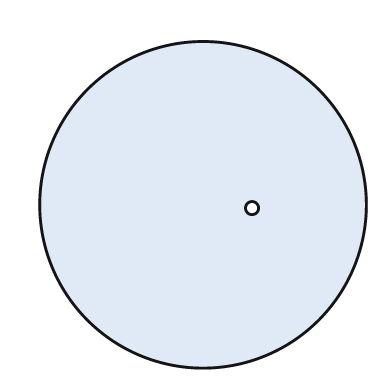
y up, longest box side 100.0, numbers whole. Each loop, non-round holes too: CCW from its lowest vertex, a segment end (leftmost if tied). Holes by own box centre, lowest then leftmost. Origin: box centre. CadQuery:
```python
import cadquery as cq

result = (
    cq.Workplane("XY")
    .moveTo(0.0, 0.0)
    .circle(50.0)
    .moveTo(15.0, -1.0)
    .circle(2.0)
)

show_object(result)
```